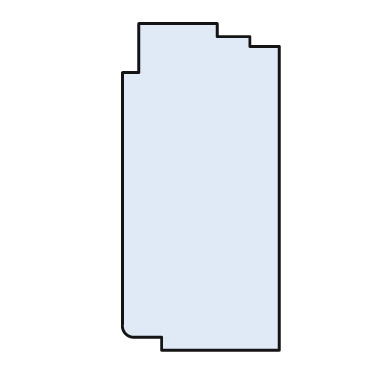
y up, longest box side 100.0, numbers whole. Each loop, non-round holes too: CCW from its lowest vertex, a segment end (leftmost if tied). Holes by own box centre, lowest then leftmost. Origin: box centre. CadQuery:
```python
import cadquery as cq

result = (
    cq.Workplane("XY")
    .moveTo(-12.0, -50.0)
    .lineTo(24.0, -50.0)
    .lineTo(24.0, 43.0)
    .lineTo(15.0, 43.0)
    .lineTo(15.0, 46.0)
    .lineTo(5.0, 46.0)
    .lineTo(5.0, 50.0)
    .lineTo(-19.0, 50.0)
    .lineTo(-19.0, 35.0)
    .lineTo(-24.0, 35.0)
    .lineTo(-24.0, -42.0)
    .threePointArc((-23.0, -45.0), (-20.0, -46.0))
    .lineTo(-12.0, -46.0)
    .close()
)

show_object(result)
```